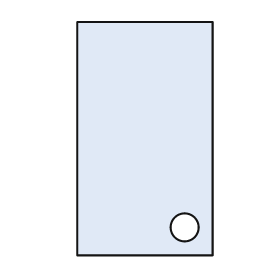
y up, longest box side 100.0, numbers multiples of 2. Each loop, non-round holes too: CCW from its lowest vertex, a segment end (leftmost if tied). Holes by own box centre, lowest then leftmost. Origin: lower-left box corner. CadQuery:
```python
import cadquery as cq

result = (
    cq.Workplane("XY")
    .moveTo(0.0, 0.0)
    .lineTo(58.0, 0.0)
    .lineTo(58.0, 100.0)
    .lineTo(0.0, 100.0)
    .close()
    .moveTo(46.0, 12.0)
    .circle(6.0)
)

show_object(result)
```